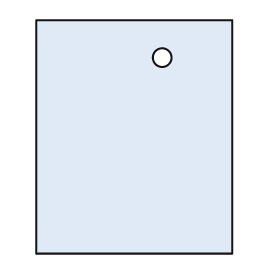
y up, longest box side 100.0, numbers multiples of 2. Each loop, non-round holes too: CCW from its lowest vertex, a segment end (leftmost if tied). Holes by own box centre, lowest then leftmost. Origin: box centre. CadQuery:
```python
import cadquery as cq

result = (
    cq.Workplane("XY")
    .moveTo(-42.0, -50.0)
    .lineTo(42.0, -50.0)
    .lineTo(42.0, 50.0)
    .lineTo(-42.0, 50.0)
    .close()
    .moveTo(12.0, 34.0)
    .circle(4.0)
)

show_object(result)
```